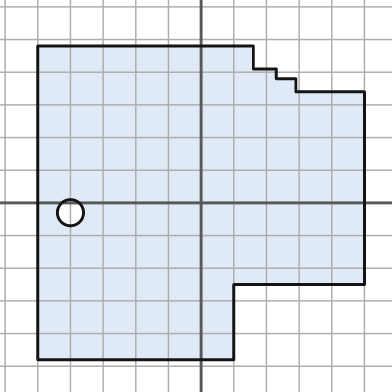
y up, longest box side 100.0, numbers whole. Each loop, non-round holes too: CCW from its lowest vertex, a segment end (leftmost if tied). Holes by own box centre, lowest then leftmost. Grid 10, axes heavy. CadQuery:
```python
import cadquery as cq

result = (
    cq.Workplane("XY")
    .moveTo(-50.0, -48.0)
    .lineTo(10.0, -48.0)
    .lineTo(10.0, -25.0)
    .lineTo(50.0, -25.0)
    .lineTo(50.0, 34.0)
    .lineTo(29.0, 34.0)
    .lineTo(29.0, 38.0)
    .lineTo(23.0, 38.0)
    .lineTo(23.0, 41.0)
    .lineTo(16.0, 41.0)
    .lineTo(16.0, 48.0)
    .lineTo(-50.0, 48.0)
    .close()
    .moveTo(-40.0, -3.0)
    .circle(4.0)
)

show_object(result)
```